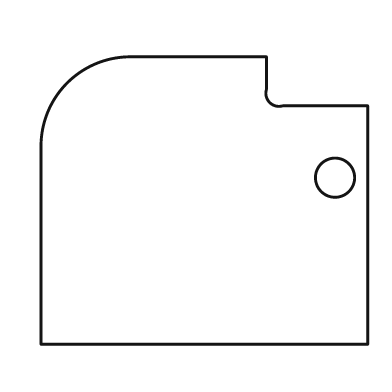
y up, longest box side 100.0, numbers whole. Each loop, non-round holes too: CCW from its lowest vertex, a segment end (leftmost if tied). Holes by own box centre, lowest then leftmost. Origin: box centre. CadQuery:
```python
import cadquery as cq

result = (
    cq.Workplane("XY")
    .moveTo(-50.0, -44.0)
    .lineTo(50.0, -44.0)
    .lineTo(50.0, 29.0)
    .lineTo(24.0, 29.0)
    .threePointArc((20.0, 30.0), (19.0, 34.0))
    .lineTo(19.0, 44.0)
    .lineTo(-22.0, 44.0)
    .threePointArc((-42.0, 36.0), (-50.0, 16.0))
    .close()
    .moveTo(40.0, 7.0)
    .circle(6.0)
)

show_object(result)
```